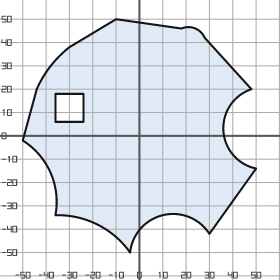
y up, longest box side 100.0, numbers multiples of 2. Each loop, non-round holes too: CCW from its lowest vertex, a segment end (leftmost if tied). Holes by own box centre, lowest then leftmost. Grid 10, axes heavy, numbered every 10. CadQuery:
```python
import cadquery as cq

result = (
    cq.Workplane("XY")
    .moveTo(-4.0, -50.0)
    .threePointArc((10.0, -34.0), (30.0, -42.0))
    .lineTo(50.0, -14.0)
    .threePointArc((36.0, 2.0), (48.0, 20.0))
    .lineTo(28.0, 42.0)
    .threePointArc((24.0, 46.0), (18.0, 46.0))
    .lineTo(-10.0, 50.0)
    .lineTo(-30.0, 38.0)
    .threePointArc((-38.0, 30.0), (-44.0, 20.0))
    .lineTo(-50.0, -2.0)
    .threePointArc((-38.0, -16.0), (-36.0, -34.0))
    .threePointArc((-18.0, -38.0), (-4.0, -50.0))
    .close()
    .moveTo(-36.0, 6.0)
    .lineTo(-24.0, 6.0)
    .lineTo(-24.0, 18.0)
    .lineTo(-36.0, 18.0)
    .close()
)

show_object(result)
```